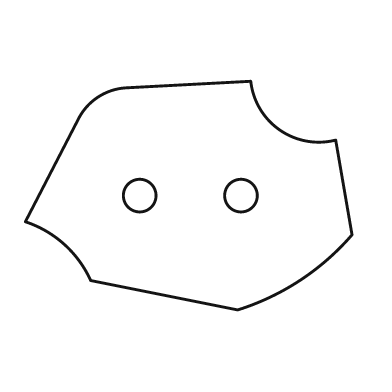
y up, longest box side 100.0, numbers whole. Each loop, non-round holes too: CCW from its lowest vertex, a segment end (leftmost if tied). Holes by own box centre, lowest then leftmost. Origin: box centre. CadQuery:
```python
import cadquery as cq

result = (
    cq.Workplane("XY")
    .moveTo(15.0, -35.0)
    .threePointArc((34.0, -26.0), (50.0, -12.0))
    .lineTo(45.0, 17.0)
    .threePointArc((28.0, 20.0), (19.0, 35.0))
    .lineTo(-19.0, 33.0)
    .threePointArc((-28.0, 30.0), (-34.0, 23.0))
    .lineTo(-50.0, -8.0)
    .threePointArc((-38.0, -15.0), (-30.0, -26.0))
    .close()
    .moveTo(-15.0, 0.0)
    .circle(5.0)
    .moveTo(16.0, 0.0)
    .circle(5.0)
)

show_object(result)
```